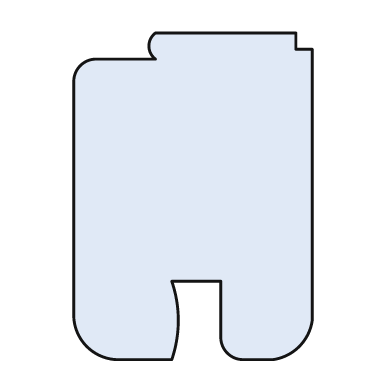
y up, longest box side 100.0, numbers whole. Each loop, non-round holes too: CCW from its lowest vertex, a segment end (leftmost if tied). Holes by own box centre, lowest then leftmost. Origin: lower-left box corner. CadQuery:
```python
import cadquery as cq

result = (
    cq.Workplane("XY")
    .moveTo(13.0, 0.0)
    .lineTo(30.0, 0.0)
    .threePointArc((32.0, 12.0), (30.0, 24.0))
    .lineTo(45.0, 24.0)
    .lineTo(45.0, 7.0)
    .threePointArc((47.0, 2.0), (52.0, 0.0))
    .lineTo(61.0, 0.0)
    .threePointArc((69.0, 4.0), (73.0, 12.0))
    .lineTo(73.0, 95.0)
    .lineTo(68.0, 95.0)
    .lineTo(68.0, 100.0)
    .lineTo(25.0, 100.0)
    .threePointArc((23.0, 96.0), (25.0, 92.0))
    .lineTo(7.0, 92.0)
    .threePointArc((2.0, 90.0), (0.0, 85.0))
    .lineTo(0.0, 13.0)
    .threePointArc((4.0, 4.0), (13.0, 0.0))
    .close()
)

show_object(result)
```